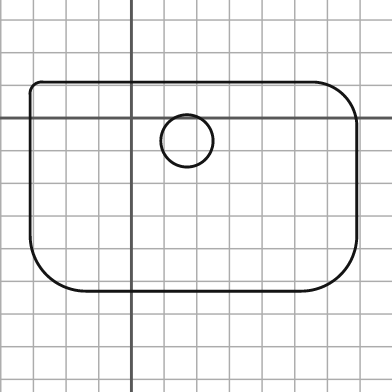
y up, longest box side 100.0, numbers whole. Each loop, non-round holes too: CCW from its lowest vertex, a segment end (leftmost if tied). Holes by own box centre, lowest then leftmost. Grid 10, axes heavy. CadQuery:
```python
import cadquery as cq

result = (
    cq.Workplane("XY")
    .moveTo(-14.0, -53.0)
    .lineTo(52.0, -53.0)
    .threePointArc((64.0, -48.0), (69.0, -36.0))
    .lineTo(69.0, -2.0)
    .threePointArc((65.0, 7.0), (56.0, 11.0))
    .lineTo(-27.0, 11.0)
    .threePointArc((-30.0, 10.0), (-31.0, 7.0))
    .lineTo(-31.0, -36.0)
    .threePointArc((-26.0, -48.0), (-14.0, -53.0))
    .close()
    .moveTo(17.0, -7.0)
    .circle(8.0)
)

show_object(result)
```